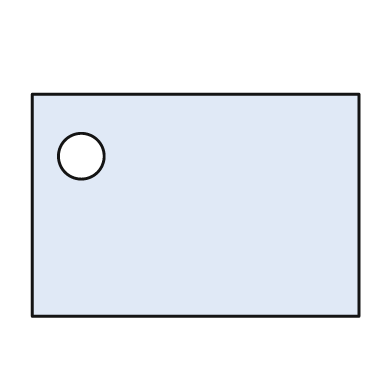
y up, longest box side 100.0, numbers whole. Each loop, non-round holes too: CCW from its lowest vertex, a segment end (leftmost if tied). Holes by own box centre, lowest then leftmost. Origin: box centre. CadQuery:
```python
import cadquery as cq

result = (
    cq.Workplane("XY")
    .moveTo(-50.0, -34.0)
    .lineTo(50.0, -34.0)
    .lineTo(50.0, 34.0)
    .lineTo(-50.0, 34.0)
    .close()
    .moveTo(-35.0, 15.0)
    .circle(7.0)
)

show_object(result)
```